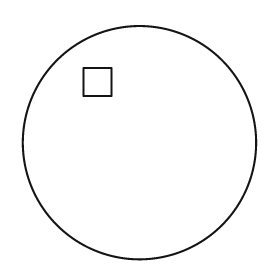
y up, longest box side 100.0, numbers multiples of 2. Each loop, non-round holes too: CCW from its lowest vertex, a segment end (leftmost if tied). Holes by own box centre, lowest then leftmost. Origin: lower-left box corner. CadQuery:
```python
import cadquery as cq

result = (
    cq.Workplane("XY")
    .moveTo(50.0, 50.0)
    .circle(50.0)
    .moveTo(26.0, 70.0)
    .lineTo(38.0, 70.0)
    .lineTo(38.0, 82.0)
    .lineTo(26.0, 82.0)
    .close()
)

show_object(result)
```